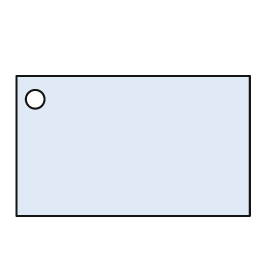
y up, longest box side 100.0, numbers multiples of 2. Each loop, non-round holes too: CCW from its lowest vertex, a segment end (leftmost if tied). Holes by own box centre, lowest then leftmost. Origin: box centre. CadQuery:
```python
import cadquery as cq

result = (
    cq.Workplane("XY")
    .moveTo(-50.0, -30.0)
    .lineTo(50.0, -30.0)
    .lineTo(50.0, 30.0)
    .lineTo(-50.0, 30.0)
    .close()
    .moveTo(-42.0, 20.0)
    .circle(4.0)
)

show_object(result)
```